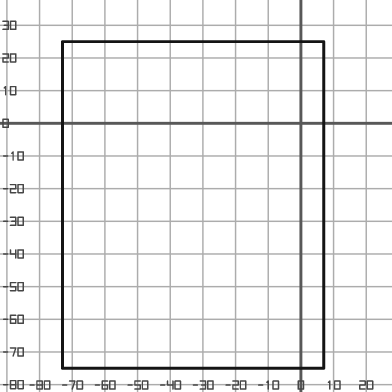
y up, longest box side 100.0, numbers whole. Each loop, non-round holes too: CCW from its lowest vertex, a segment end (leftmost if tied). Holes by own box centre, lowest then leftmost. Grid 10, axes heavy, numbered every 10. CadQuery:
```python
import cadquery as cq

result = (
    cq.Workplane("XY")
    .moveTo(-73.0, -75.0)
    .lineTo(7.0, -75.0)
    .lineTo(7.0, 25.0)
    .lineTo(-73.0, 25.0)
    .close()
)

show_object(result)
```